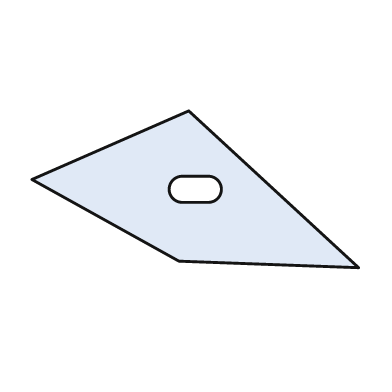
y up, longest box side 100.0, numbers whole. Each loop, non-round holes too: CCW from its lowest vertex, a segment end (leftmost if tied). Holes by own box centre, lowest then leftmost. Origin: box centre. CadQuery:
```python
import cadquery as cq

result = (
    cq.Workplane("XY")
    .moveTo(50.0, -24.0)
    .lineTo(-2.0, 24.0)
    .lineTo(-50.0, 3.0)
    .lineTo(-5.0, -22.0)
    .close()
    .moveTo(-4.0, -4.0)
    .lineTo(4.0, -4.0)
    .threePointArc((8.0, 0.0), (4.0, 4.0))
    .lineTo(-4.0, 4.0)
    .threePointArc((-8.0, 0.0), (-4.0, -4.0))
    .close()
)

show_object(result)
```